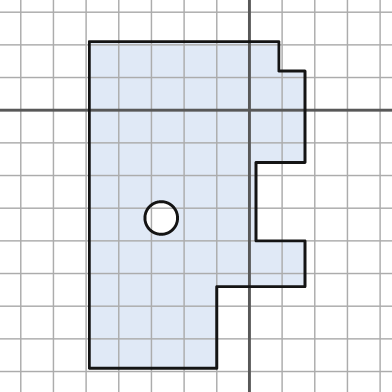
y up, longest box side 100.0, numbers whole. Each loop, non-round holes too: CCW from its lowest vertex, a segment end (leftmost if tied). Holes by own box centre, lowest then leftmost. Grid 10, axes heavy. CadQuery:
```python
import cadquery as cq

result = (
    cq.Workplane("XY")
    .moveTo(-49.0, -79.0)
    .lineTo(-10.0, -79.0)
    .lineTo(-10.0, -54.0)
    .lineTo(17.0, -54.0)
    .lineTo(17.0, -40.0)
    .lineTo(2.0, -40.0)
    .lineTo(2.0, -16.0)
    .lineTo(17.0, -16.0)
    .lineTo(17.0, 12.0)
    .lineTo(9.0, 12.0)
    .lineTo(9.0, 21.0)
    .lineTo(-49.0, 21.0)
    .close()
    .moveTo(-27.0, -33.0)
    .circle(5.0)
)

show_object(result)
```